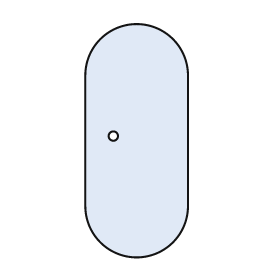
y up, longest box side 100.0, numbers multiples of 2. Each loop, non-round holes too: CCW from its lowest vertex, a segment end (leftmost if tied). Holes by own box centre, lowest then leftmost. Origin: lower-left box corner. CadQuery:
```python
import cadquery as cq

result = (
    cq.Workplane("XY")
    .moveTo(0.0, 22.0)
    .threePointArc((22.0, 0.0), (44.0, 22.0))
    .lineTo(44.0, 78.0)
    .threePointArc((22.0, 100.0), (0.0, 78.0))
    .close()
    .moveTo(12.0, 52.0)
    .circle(2.0)
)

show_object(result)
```